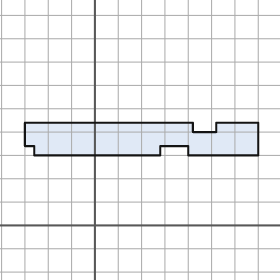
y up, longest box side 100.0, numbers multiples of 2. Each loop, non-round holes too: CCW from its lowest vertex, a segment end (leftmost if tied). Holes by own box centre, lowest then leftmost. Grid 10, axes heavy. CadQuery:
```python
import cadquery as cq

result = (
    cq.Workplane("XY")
    .moveTo(-26.0, 30.0)
    .lineTo(28.0, 30.0)
    .lineTo(28.0, 34.0)
    .lineTo(40.0, 34.0)
    .lineTo(40.0, 30.0)
    .lineTo(70.0, 30.0)
    .lineTo(70.0, 44.0)
    .lineTo(52.0, 44.0)
    .lineTo(52.0, 40.0)
    .lineTo(42.0, 40.0)
    .lineTo(42.0, 44.0)
    .lineTo(-30.0, 44.0)
    .lineTo(-30.0, 34.0)
    .lineTo(-26.0, 34.0)
    .close()
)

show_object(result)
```